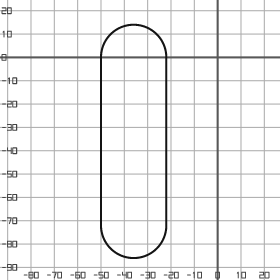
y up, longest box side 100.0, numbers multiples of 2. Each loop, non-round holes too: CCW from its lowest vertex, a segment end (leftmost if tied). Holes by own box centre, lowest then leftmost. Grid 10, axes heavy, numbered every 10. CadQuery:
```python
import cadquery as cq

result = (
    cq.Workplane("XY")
    .moveTo(-50.0, -72.0)
    .threePointArc((-36.0, -86.0), (-22.0, -72.0))
    .lineTo(-22.0, 0.0)
    .threePointArc((-36.0, 14.0), (-50.0, 0.0))
    .close()
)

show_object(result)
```